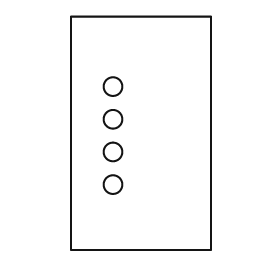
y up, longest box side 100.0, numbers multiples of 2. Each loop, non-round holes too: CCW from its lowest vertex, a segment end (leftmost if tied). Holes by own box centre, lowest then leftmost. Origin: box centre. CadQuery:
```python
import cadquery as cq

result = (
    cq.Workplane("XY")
    .moveTo(-30.0, -50.0)
    .lineTo(30.0, -50.0)
    .lineTo(30.0, 50.0)
    .lineTo(-30.0, 50.0)
    .close()
    .moveTo(-12.0, -22.0)
    .circle(4.0)
    .moveTo(-12.0, -8.0)
    .circle(4.0)
    .moveTo(-12.0, 6.0)
    .circle(4.0)
    .moveTo(-12.0, 20.0)
    .circle(4.0)
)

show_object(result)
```